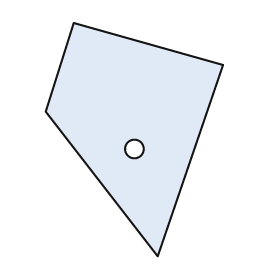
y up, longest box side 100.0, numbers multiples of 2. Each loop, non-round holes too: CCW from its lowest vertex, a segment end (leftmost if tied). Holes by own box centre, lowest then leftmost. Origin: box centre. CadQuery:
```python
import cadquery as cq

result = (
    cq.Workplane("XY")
    .moveTo(10.0, -50.0)
    .lineTo(38.0, 32.0)
    .lineTo(-26.0, 50.0)
    .lineTo(-38.0, 12.0)
    .close()
    .moveTo(0.0, -4.0)
    .circle(4.0)
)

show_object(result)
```